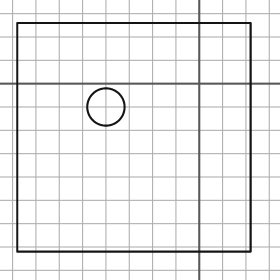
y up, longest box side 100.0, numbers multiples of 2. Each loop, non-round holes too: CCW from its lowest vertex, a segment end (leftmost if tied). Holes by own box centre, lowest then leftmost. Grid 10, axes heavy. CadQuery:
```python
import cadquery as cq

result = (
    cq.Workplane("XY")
    .moveTo(-78.0, -72.0)
    .lineTo(22.0, -72.0)
    .lineTo(22.0, 26.0)
    .lineTo(-78.0, 26.0)
    .close()
    .moveTo(-40.0, -10.0)
    .circle(8.0)
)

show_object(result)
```